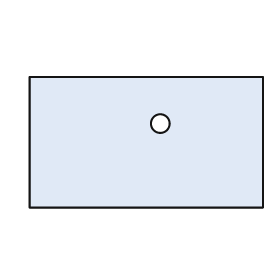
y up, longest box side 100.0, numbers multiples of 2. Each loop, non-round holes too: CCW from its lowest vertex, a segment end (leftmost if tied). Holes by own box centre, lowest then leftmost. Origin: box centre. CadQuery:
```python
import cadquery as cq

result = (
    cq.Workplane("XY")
    .moveTo(-50.0, -28.0)
    .lineTo(50.0, -28.0)
    .lineTo(50.0, 28.0)
    .lineTo(-50.0, 28.0)
    .close()
    .moveTo(6.0, 8.0)
    .circle(4.0)
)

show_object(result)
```